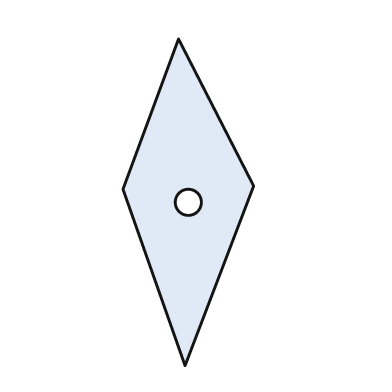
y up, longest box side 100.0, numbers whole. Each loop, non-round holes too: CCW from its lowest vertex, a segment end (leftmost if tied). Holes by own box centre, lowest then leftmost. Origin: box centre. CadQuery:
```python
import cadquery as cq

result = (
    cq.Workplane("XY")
    .moveTo(-1.0, -50.0)
    .lineTo(20.0, 5.0)
    .lineTo(-3.0, 50.0)
    .lineTo(-20.0, 4.0)
    .close()
    .moveTo(0.0, 0.0)
    .circle(4.0)
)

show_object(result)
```